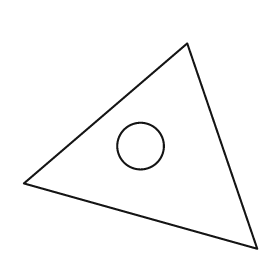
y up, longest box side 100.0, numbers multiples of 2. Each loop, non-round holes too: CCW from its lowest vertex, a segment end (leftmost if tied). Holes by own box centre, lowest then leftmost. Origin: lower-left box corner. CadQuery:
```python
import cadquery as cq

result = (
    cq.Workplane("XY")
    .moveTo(100.0, 0.0)
    .lineTo(70.0, 88.0)
    .lineTo(0.0, 28.0)
    .close()
    .moveTo(50.0, 44.0)
    .circle(10.0)
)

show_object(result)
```